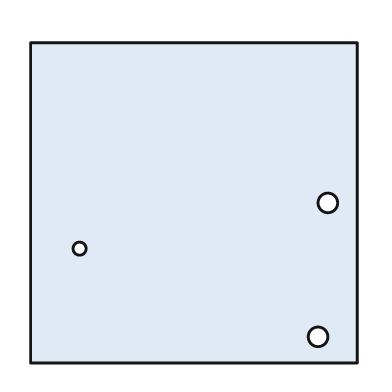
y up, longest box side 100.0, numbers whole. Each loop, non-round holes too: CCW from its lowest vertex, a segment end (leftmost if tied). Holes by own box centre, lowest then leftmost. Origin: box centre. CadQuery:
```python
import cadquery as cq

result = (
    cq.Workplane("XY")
    .moveTo(-50.0, -49.0)
    .lineTo(50.0, -49.0)
    .lineTo(50.0, 49.0)
    .lineTo(-50.0, 49.0)
    .close()
    .moveTo(38.0, -41.0)
    .circle(3.0)
    .moveTo(-35.0, -14.0)
    .circle(2.0)
    .moveTo(41.0, 0.0)
    .circle(3.0)
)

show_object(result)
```